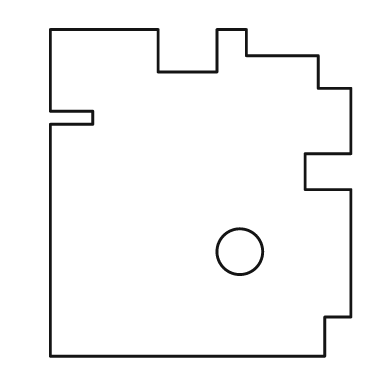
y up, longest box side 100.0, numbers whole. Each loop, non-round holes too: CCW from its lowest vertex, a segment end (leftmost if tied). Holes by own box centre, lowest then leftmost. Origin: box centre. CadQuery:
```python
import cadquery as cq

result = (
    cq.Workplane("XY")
    .moveTo(-46.0, -50.0)
    .lineTo(38.0, -50.0)
    .lineTo(38.0, -38.0)
    .lineTo(46.0, -38.0)
    .lineTo(46.0, 1.0)
    .lineTo(32.0, 1.0)
    .lineTo(32.0, 12.0)
    .lineTo(46.0, 12.0)
    .lineTo(46.0, 32.0)
    .lineTo(36.0, 32.0)
    .lineTo(36.0, 42.0)
    .lineTo(14.0, 42.0)
    .lineTo(14.0, 50.0)
    .lineTo(5.0, 50.0)
    .lineTo(5.0, 37.0)
    .lineTo(-13.0, 37.0)
    .lineTo(-13.0, 50.0)
    .lineTo(-46.0, 50.0)
    .lineTo(-46.0, 25.0)
    .lineTo(-33.0, 25.0)
    .lineTo(-33.0, 21.0)
    .lineTo(-46.0, 21.0)
    .close()
    .moveTo(12.0, -18.0)
    .circle(7.0)
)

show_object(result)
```